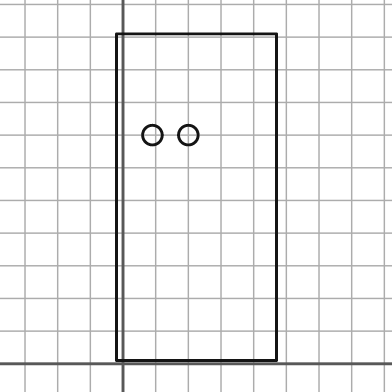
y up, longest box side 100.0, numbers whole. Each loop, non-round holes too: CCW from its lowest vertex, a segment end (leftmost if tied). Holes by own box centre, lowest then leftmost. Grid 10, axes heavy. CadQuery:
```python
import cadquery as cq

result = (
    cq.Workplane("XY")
    .moveTo(-2.0, 1.0)
    .lineTo(47.0, 1.0)
    .lineTo(47.0, 101.0)
    .lineTo(-2.0, 101.0)
    .close()
    .moveTo(9.0, 70.0)
    .circle(3.0)
    .moveTo(20.0, 70.0)
    .circle(3.0)
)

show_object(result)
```